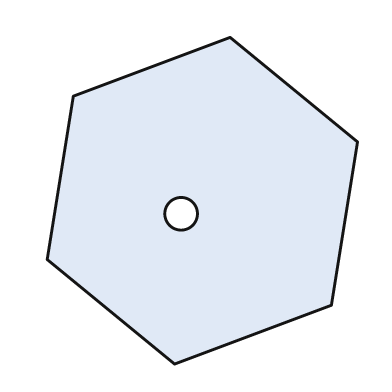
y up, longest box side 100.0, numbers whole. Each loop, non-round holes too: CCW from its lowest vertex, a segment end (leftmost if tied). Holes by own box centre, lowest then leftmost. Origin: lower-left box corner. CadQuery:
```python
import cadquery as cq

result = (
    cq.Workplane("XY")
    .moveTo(39.0, 0.0)
    .lineTo(87.0, 18.0)
    .lineTo(95.0, 68.0)
    .lineTo(56.0, 100.0)
    .lineTo(8.0, 82.0)
    .lineTo(0.0, 32.0)
    .close()
    .moveTo(41.0, 46.0)
    .circle(5.0)
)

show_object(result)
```